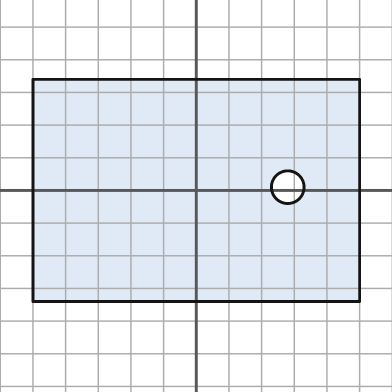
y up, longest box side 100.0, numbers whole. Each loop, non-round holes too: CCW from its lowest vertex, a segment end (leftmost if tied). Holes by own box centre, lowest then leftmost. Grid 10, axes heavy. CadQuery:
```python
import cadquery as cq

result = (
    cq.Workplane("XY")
    .moveTo(-50.0, -34.0)
    .lineTo(50.0, -34.0)
    .lineTo(50.0, 34.0)
    .lineTo(-50.0, 34.0)
    .close()
    .moveTo(28.0, 1.0)
    .circle(5.0)
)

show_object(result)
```